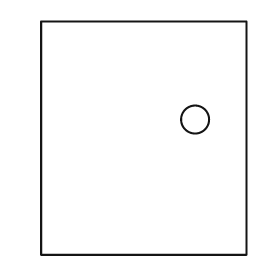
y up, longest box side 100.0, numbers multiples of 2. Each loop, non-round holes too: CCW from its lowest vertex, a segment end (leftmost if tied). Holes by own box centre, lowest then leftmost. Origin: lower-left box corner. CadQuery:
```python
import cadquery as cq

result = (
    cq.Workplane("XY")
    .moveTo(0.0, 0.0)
    .lineTo(88.0, 0.0)
    .lineTo(88.0, 100.0)
    .lineTo(0.0, 100.0)
    .close()
    .moveTo(66.0, 58.0)
    .circle(6.0)
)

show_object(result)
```